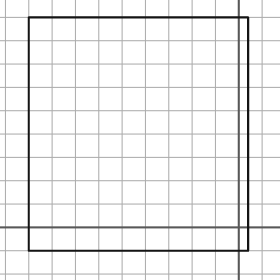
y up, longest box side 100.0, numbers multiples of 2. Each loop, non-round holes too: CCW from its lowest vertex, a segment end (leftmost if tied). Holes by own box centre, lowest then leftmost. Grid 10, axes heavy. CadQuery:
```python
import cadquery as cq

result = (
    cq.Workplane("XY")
    .moveTo(-90.0, -10.0)
    .lineTo(4.0, -10.0)
    .lineTo(4.0, 90.0)
    .lineTo(-90.0, 90.0)
    .close()
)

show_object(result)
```